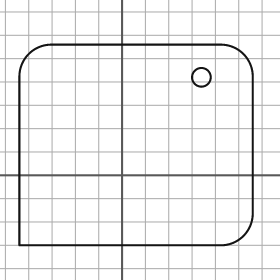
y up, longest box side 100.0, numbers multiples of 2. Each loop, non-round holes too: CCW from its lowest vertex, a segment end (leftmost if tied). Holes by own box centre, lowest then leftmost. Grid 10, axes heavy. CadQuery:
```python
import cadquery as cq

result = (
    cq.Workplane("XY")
    .moveTo(-44.0, -30.0)
    .lineTo(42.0, -30.0)
    .threePointArc((52.0, -26.0), (56.0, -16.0))
    .lineTo(56.0, 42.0)
    .threePointArc((52.0, 52.0), (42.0, 56.0))
    .lineTo(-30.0, 56.0)
    .threePointArc((-40.0, 52.0), (-44.0, 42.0))
    .close()
    .moveTo(34.0, 42.0)
    .circle(4.0)
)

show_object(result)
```